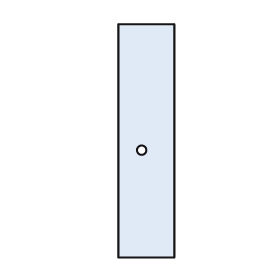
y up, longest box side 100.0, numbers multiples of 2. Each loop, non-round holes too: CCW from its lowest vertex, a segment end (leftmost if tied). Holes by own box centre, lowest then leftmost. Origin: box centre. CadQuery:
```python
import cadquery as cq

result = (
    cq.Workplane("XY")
    .moveTo(-12.0, -50.0)
    .lineTo(12.0, -50.0)
    .lineTo(12.0, 50.0)
    .lineTo(-12.0, 50.0)
    .close()
    .moveTo(-2.0, -4.0)
    .circle(2.0)
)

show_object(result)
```